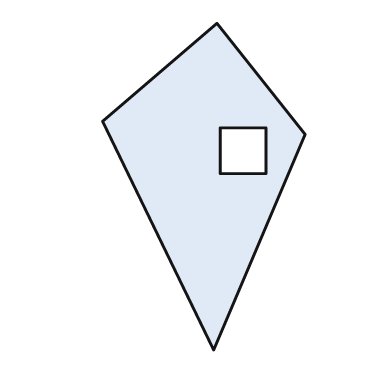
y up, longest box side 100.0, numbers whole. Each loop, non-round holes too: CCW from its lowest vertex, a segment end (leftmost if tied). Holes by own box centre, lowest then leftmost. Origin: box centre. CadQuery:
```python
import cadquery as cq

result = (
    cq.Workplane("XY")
    .moveTo(3.0, -50.0)
    .lineTo(31.0, 16.0)
    .lineTo(4.0, 50.0)
    .lineTo(-31.0, 20.0)
    .close()
    .moveTo(5.0, 4.0)
    .lineTo(19.0, 4.0)
    .lineTo(19.0, 18.0)
    .lineTo(5.0, 18.0)
    .close()
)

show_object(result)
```